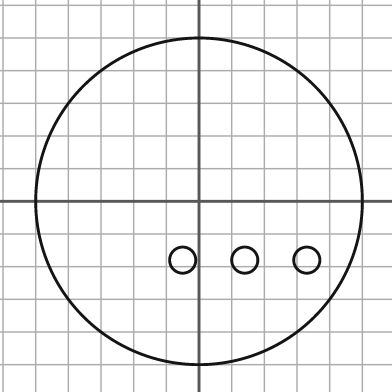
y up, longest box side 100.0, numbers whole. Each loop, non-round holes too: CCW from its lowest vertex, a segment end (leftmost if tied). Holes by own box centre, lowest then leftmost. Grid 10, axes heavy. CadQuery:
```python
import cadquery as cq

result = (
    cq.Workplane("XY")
    .moveTo(0.0, 0.0)
    .circle(50.0)
    .moveTo(-5.0, -18.0)
    .circle(4.0)
    .moveTo(14.0, -18.0)
    .circle(4.0)
    .moveTo(33.0, -18.0)
    .circle(4.0)
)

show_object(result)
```